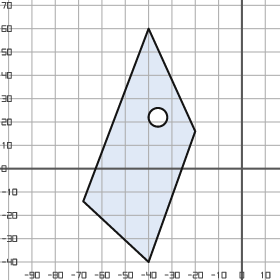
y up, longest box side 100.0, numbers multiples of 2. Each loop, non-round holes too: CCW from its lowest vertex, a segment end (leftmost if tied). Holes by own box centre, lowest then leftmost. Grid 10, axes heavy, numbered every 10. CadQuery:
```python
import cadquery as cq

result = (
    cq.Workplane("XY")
    .moveTo(-40.0, -40.0)
    .lineTo(-20.0, 16.0)
    .lineTo(-40.0, 60.0)
    .lineTo(-68.0, -14.0)
    .close()
    .moveTo(-36.0, 22.0)
    .circle(4.0)
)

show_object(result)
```